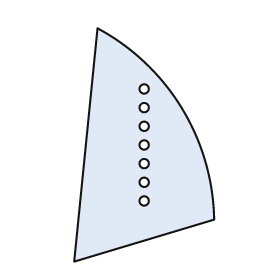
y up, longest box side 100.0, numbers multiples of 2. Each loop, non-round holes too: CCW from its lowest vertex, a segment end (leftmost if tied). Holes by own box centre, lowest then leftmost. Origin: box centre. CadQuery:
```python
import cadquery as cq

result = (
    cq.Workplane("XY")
    .moveTo(-30.0, -50.0)
    .lineTo(30.0, -32.0)
    .threePointArc((16.0, 16.0), (-20.0, 50.0))
    .close()
    .moveTo(0.0, -24.0)
    .circle(2.0)
    .moveTo(0.0, -16.0)
    .circle(2.0)
    .moveTo(0.0, -8.0)
    .circle(2.0)
    .moveTo(0.0, 0.0)
    .circle(2.0)
    .moveTo(0.0, 8.0)
    .circle(2.0)
    .moveTo(0.0, 16.0)
    .circle(2.0)
    .moveTo(0.0, 24.0)
    .circle(2.0)
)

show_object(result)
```